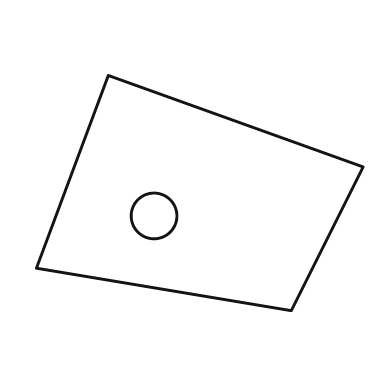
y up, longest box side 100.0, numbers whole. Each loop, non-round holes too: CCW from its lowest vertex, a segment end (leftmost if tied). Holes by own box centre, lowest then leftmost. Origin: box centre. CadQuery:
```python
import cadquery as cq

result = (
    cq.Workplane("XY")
    .moveTo(28.0, -36.0)
    .lineTo(50.0, 8.0)
    .lineTo(-28.0, 36.0)
    .lineTo(-50.0, -23.0)
    .close()
    .moveTo(-14.0, -7.0)
    .circle(7.0)
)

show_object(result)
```